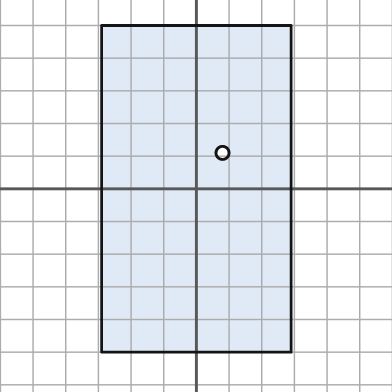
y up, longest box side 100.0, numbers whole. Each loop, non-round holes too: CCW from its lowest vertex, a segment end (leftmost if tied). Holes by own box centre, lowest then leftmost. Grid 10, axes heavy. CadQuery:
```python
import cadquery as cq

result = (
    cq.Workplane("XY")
    .moveTo(-29.0, -50.0)
    .lineTo(29.0, -50.0)
    .lineTo(29.0, 50.0)
    .lineTo(-29.0, 50.0)
    .close()
    .moveTo(8.0, 11.0)
    .circle(2.0)
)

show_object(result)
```